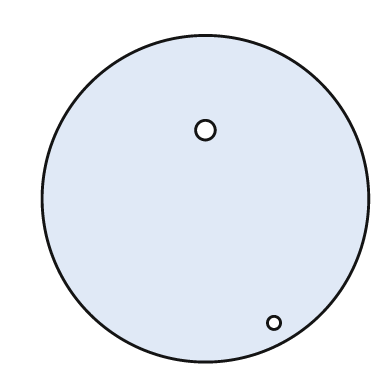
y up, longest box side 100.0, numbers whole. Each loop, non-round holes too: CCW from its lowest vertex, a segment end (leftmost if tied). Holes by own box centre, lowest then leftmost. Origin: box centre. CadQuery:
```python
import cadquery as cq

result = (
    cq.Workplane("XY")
    .moveTo(0.0, 0.0)
    .circle(50.0)
    .moveTo(21.0, -38.0)
    .circle(2.0)
    .moveTo(0.0, 21.0)
    .circle(3.0)
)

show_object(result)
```